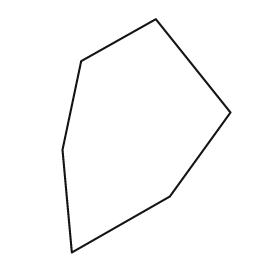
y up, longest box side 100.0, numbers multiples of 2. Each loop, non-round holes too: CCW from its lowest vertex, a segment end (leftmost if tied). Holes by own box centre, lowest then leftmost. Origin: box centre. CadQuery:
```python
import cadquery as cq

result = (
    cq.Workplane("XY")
    .moveTo(-32.0, -50.0)
    .lineTo(10.0, -26.0)
    .lineTo(36.0, 10.0)
    .lineTo(4.0, 50.0)
    .lineTo(-28.0, 32.0)
    .lineTo(-36.0, -6.0)
    .close()
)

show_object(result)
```